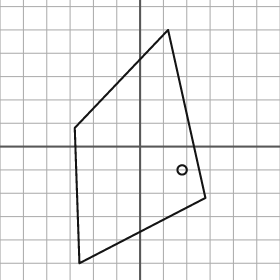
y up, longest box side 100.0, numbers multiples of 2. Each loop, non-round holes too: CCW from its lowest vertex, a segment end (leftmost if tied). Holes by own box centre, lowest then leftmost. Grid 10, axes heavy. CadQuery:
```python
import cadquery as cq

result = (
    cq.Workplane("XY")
    .moveTo(-26.0, -50.0)
    .lineTo(28.0, -22.0)
    .lineTo(12.0, 50.0)
    .lineTo(-28.0, 8.0)
    .close()
    .moveTo(18.0, -10.0)
    .circle(2.0)
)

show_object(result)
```